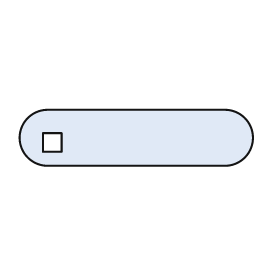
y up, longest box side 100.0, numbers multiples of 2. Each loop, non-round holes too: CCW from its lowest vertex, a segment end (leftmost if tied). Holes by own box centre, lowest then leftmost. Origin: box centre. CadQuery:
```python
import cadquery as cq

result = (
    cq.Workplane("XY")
    .moveTo(-38.0, -12.0)
    .lineTo(38.0, -12.0)
    .threePointArc((50.0, 0.0), (38.0, 12.0))
    .lineTo(-38.0, 12.0)
    .threePointArc((-50.0, 0.0), (-38.0, -12.0))
    .close()
    .moveTo(-40.0, -6.0)
    .lineTo(-32.0, -6.0)
    .lineTo(-32.0, 2.0)
    .lineTo(-40.0, 2.0)
    .close()
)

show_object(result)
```